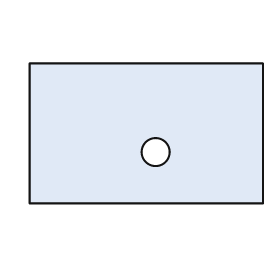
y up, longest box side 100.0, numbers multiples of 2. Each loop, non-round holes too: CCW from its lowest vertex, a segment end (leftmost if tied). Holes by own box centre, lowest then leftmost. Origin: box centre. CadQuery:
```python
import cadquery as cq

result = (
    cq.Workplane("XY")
    .moveTo(-50.0, -30.0)
    .lineTo(50.0, -30.0)
    .lineTo(50.0, 30.0)
    .lineTo(-50.0, 30.0)
    .close()
    .moveTo(4.0, -8.0)
    .circle(6.0)
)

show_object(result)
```